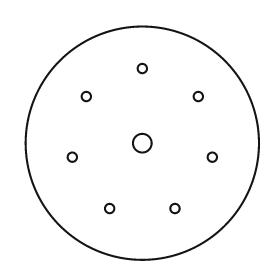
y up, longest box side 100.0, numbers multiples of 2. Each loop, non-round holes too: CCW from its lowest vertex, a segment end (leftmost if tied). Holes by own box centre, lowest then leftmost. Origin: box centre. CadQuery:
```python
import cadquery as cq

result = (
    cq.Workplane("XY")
    .moveTo(0.0, 0.0)
    .circle(50.0)
    .moveTo(-14.0, -28.0)
    .circle(2.0)
    .moveTo(14.0, -28.0)
    .circle(2.0)
    .moveTo(-30.0, -6.0)
    .circle(2.0)
    .moveTo(30.0, -6.0)
    .circle(2.0)
    .moveTo(0.0, 0.0)
    .circle(4.0)
    .moveTo(-24.0, 20.0)
    .circle(2.0)
    .moveTo(24.0, 20.0)
    .circle(2.0)
    .moveTo(0.0, 32.0)
    .circle(2.0)
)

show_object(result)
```